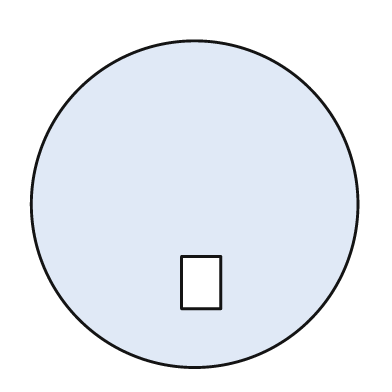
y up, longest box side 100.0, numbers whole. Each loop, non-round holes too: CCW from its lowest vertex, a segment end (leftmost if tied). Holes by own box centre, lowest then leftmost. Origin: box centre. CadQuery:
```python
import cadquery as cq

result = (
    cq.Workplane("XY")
    .moveTo(0.0, 0.0)
    .circle(50.0)
    .moveTo(-4.0, -32.0)
    .lineTo(8.0, -32.0)
    .lineTo(8.0, -16.0)
    .lineTo(-4.0, -16.0)
    .close()
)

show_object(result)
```